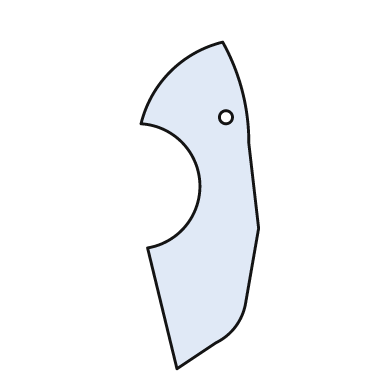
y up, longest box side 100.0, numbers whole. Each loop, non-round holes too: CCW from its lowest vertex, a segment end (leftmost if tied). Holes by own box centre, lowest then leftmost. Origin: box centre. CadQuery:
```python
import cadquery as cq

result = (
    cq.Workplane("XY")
    .moveTo(-7.0, -50.0)
    .lineTo(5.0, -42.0)
    .threePointArc((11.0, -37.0), (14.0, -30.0))
    .lineTo(18.0, -7.0)
    .lineTo(15.0, 19.0)
    .threePointArc((13.0, 35.0), (7.0, 50.0))
    .threePointArc((-9.0, 41.0), (-18.0, 25.0))
    .threePointArc((0.0, 7.0), (-16.0, -13.0))
    .close()
    .moveTo(8.0, 27.0)
    .circle(2.0)
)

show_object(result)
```